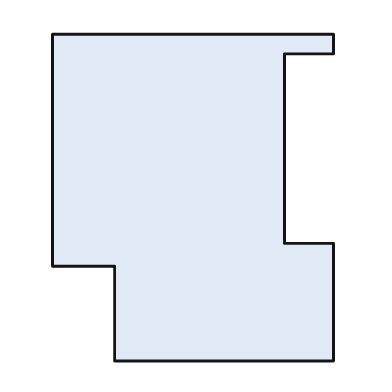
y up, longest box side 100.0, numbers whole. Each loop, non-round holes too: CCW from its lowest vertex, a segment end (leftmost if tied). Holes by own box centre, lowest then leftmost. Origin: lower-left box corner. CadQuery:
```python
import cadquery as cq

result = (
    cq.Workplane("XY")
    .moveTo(19.0, 0.0)
    .lineTo(86.0, 0.0)
    .lineTo(86.0, 36.0)
    .lineTo(71.0, 36.0)
    .lineTo(71.0, 94.0)
    .lineTo(86.0, 94.0)
    .lineTo(86.0, 100.0)
    .lineTo(0.0, 100.0)
    .lineTo(0.0, 29.0)
    .lineTo(19.0, 29.0)
    .close()
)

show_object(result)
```